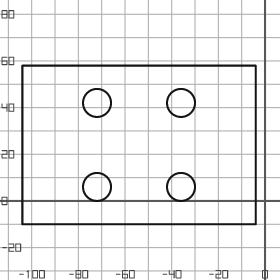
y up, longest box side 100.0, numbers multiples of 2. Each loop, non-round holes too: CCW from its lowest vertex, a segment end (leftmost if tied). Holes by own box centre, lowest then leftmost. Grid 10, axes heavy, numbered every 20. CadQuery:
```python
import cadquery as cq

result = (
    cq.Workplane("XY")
    .moveTo(-104.0, -10.0)
    .lineTo(-4.0, -10.0)
    .lineTo(-4.0, 58.0)
    .lineTo(-104.0, 58.0)
    .close()
    .moveTo(-72.0, 6.0)
    .circle(6.0)
    .moveTo(-36.0, 6.0)
    .circle(6.0)
    .moveTo(-72.0, 42.0)
    .circle(6.0)
    .moveTo(-36.0, 42.0)
    .circle(6.0)
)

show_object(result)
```